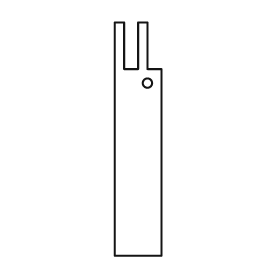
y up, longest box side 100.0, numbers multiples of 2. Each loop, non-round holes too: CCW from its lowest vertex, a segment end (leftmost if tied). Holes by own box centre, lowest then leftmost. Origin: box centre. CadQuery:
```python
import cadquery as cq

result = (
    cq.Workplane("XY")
    .moveTo(-10.0, -50.0)
    .lineTo(10.0, -50.0)
    .lineTo(10.0, 30.0)
    .lineTo(4.0, 30.0)
    .lineTo(4.0, 50.0)
    .lineTo(0.0, 50.0)
    .lineTo(0.0, 30.0)
    .lineTo(-6.0, 30.0)
    .lineTo(-6.0, 50.0)
    .lineTo(-10.0, 50.0)
    .close()
    .moveTo(4.0, 24.0)
    .circle(2.0)
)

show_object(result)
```